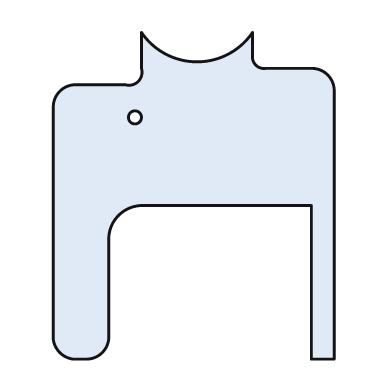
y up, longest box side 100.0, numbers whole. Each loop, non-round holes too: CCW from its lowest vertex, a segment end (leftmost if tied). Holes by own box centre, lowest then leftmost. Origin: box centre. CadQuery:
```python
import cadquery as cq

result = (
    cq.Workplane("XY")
    .moveTo(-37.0, -50.0)
    .lineTo(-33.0, -50.0)
    .threePointArc((-28.0, -48.0), (-26.0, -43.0))
    .lineTo(-26.0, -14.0)
    .threePointArc((-23.0, -6.0), (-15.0, -3.0))
    .lineTo(36.0, -3.0)
    .lineTo(36.0, -50.0)
    .lineTo(43.0, -50.0)
    .lineTo(43.0, 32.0)
    .threePointArc((41.0, 37.0), (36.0, 39.0))
    .lineTo(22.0, 39.0)
    .threePointArc((19.0, 40.0), (18.0, 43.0))
    .lineTo(18.0, 50.0)
    .threePointArc((1.0, 41.0), (-16.0, 50.0))
    .lineTo(-16.0, 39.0)
    .threePointArc((-17.0, 35.0), (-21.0, 34.0))
    .lineTo(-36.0, 34.0)
    .threePointArc((-41.0, 32.0), (-43.0, 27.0))
    .lineTo(-43.0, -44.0)
    .threePointArc((-41.0, -48.0), (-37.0, -50.0))
    .close()
    .moveTo(-18.0, 24.0)
    .circle(2.0)
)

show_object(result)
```